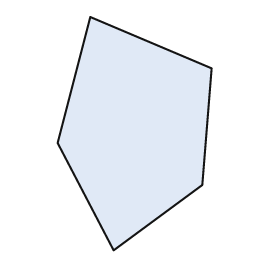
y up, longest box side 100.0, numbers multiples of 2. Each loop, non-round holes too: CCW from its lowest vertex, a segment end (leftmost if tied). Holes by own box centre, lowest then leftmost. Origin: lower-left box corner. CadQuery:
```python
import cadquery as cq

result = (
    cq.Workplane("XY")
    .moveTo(24.0, 0.0)
    .lineTo(62.0, 28.0)
    .lineTo(66.0, 78.0)
    .lineTo(14.0, 100.0)
    .lineTo(0.0, 46.0)
    .close()
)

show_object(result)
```